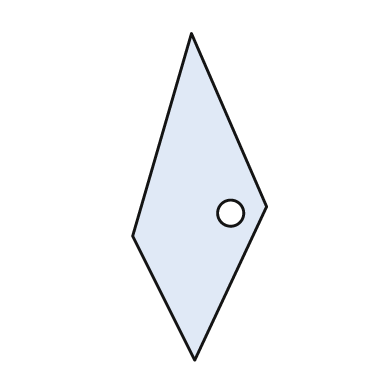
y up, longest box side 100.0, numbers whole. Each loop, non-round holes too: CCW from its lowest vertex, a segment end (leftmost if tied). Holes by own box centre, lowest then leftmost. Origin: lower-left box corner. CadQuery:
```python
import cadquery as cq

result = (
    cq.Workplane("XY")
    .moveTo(19.0, 0.0)
    .lineTo(41.0, 47.0)
    .lineTo(18.0, 100.0)
    .lineTo(0.0, 38.0)
    .close()
    .moveTo(30.0, 45.0)
    .circle(4.0)
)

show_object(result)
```